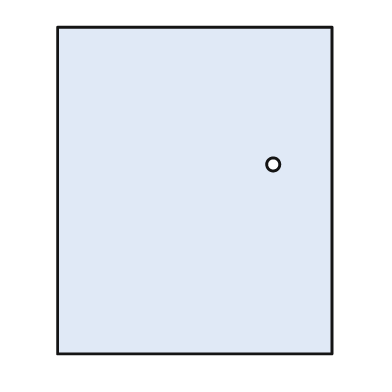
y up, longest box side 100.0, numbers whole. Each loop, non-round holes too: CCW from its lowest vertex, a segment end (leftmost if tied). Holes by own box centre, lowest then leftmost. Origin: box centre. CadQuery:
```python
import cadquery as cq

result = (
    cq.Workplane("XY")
    .moveTo(-42.0, -50.0)
    .lineTo(42.0, -50.0)
    .lineTo(42.0, 50.0)
    .lineTo(-42.0, 50.0)
    .close()
    .moveTo(24.0, 8.0)
    .circle(2.0)
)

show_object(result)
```